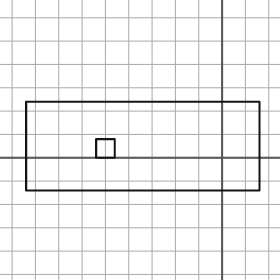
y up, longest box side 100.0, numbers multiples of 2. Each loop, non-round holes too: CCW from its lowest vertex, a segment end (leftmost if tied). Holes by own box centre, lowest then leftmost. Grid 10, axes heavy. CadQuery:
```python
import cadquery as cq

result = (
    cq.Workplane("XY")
    .moveTo(-84.0, -14.0)
    .lineTo(16.0, -14.0)
    .lineTo(16.0, 24.0)
    .lineTo(-84.0, 24.0)
    .close()
    .moveTo(-54.0, 0.0)
    .lineTo(-46.0, 0.0)
    .lineTo(-46.0, 8.0)
    .lineTo(-54.0, 8.0)
    .close()
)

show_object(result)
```